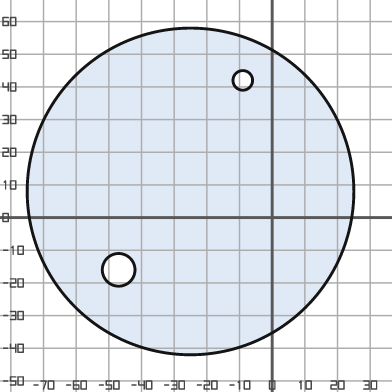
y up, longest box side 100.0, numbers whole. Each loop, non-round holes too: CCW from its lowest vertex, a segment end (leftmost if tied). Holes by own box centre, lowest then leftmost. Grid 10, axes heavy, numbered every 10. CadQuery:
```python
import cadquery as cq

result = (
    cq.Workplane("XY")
    .moveTo(-25.0, 8.0)
    .circle(50.0)
    .moveTo(-47.0, -16.0)
    .circle(5.0)
    .moveTo(-9.0, 42.0)
    .circle(3.0)
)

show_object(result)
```